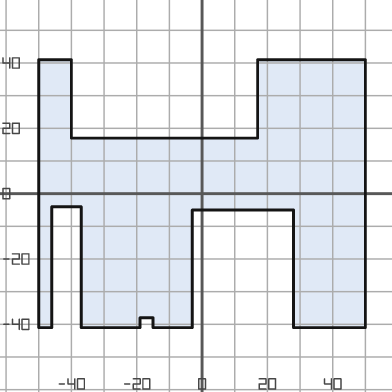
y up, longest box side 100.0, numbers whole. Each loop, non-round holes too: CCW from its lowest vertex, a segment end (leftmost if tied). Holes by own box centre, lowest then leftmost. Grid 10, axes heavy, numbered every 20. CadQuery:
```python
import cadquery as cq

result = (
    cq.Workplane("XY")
    .moveTo(-50.0, -41.0)
    .lineTo(-46.0, -41.0)
    .lineTo(-46.0, -4.0)
    .lineTo(-37.0, -4.0)
    .lineTo(-37.0, -41.0)
    .lineTo(-19.0, -41.0)
    .lineTo(-19.0, -38.0)
    .lineTo(-15.0, -38.0)
    .lineTo(-15.0, -41.0)
    .lineTo(-3.0, -41.0)
    .lineTo(-3.0, -5.0)
    .lineTo(28.0, -5.0)
    .lineTo(28.0, -41.0)
    .lineTo(50.0, -41.0)
    .lineTo(50.0, 41.0)
    .lineTo(17.0, 41.0)
    .lineTo(17.0, 17.0)
    .lineTo(-40.0, 17.0)
    .lineTo(-40.0, 41.0)
    .lineTo(-50.0, 41.0)
    .close()
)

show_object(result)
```